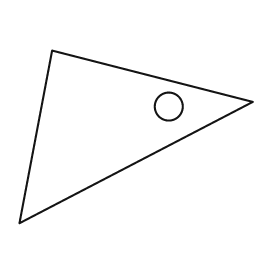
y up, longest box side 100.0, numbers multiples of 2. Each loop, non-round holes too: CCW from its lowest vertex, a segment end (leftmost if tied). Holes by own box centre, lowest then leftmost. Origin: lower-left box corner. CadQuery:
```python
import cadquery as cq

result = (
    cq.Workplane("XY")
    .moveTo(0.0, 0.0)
    .lineTo(100.0, 52.0)
    .lineTo(14.0, 74.0)
    .close()
    .moveTo(64.0, 50.0)
    .circle(6.0)
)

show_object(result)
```